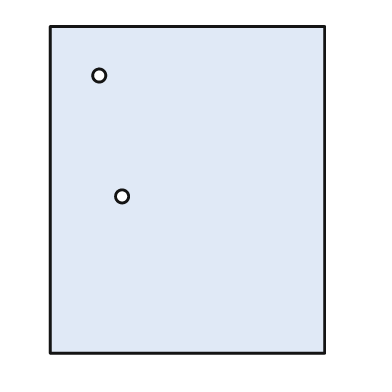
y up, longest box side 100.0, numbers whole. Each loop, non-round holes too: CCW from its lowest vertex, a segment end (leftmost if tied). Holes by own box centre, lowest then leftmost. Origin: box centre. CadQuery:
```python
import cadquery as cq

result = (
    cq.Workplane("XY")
    .moveTo(-42.0, -50.0)
    .lineTo(42.0, -50.0)
    .lineTo(42.0, 50.0)
    .lineTo(-42.0, 50.0)
    .close()
    .moveTo(-20.0, -2.0)
    .circle(2.0)
    .moveTo(-27.0, 35.0)
    .circle(2.0)
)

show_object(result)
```